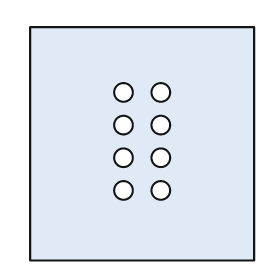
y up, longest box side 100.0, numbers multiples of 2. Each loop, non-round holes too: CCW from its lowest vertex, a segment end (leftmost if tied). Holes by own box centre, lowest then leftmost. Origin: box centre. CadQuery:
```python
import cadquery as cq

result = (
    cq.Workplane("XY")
    .moveTo(-48.0, -50.0)
    .lineTo(48.0, -50.0)
    .lineTo(48.0, 50.0)
    .lineTo(-48.0, 50.0)
    .close()
    .moveTo(-8.0, -20.0)
    .circle(4.0)
    .moveTo(8.0, -20.0)
    .circle(4.0)
    .moveTo(-8.0, -6.0)
    .circle(4.0)
    .moveTo(8.0, -6.0)
    .circle(4.0)
    .moveTo(-8.0, 8.0)
    .circle(4.0)
    .moveTo(8.0, 8.0)
    .circle(4.0)
    .moveTo(-8.0, 22.0)
    .circle(4.0)
    .moveTo(8.0, 22.0)
    .circle(4.0)
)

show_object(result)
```